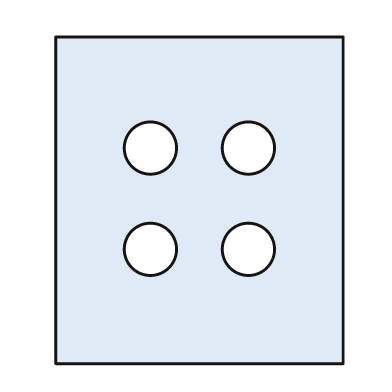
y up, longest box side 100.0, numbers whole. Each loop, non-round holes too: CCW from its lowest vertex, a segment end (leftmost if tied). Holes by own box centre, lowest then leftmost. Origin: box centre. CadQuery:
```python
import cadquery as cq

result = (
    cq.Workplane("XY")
    .moveTo(-44.0, -50.0)
    .lineTo(44.0, -50.0)
    .lineTo(44.0, 50.0)
    .lineTo(-44.0, 50.0)
    .close()
    .moveTo(-15.0, -15.0)
    .circle(8.0)
    .moveTo(15.0, -15.0)
    .circle(8.0)
    .moveTo(-15.0, 16.0)
    .circle(8.0)
    .moveTo(15.0, 16.0)
    .circle(8.0)
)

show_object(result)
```